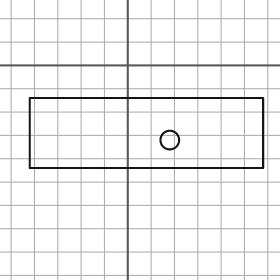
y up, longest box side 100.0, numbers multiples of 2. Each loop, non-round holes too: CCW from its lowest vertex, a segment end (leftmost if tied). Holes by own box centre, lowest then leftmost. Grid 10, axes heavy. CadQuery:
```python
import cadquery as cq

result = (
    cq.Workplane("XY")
    .moveTo(-42.0, -44.0)
    .lineTo(58.0, -44.0)
    .lineTo(58.0, -14.0)
    .lineTo(-42.0, -14.0)
    .close()
    .moveTo(18.0, -32.0)
    .circle(4.0)
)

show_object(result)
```